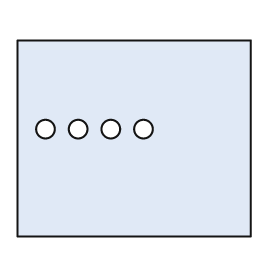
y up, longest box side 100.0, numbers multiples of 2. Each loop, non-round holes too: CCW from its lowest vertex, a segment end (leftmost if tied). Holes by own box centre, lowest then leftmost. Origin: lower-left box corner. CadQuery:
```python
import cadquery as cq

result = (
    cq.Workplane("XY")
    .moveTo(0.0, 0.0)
    .lineTo(100.0, 0.0)
    .lineTo(100.0, 84.0)
    .lineTo(0.0, 84.0)
    .close()
    .moveTo(12.0, 46.0)
    .circle(4.0)
    .moveTo(26.0, 46.0)
    .circle(4.0)
    .moveTo(40.0, 46.0)
    .circle(4.0)
    .moveTo(54.0, 46.0)
    .circle(4.0)
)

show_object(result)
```